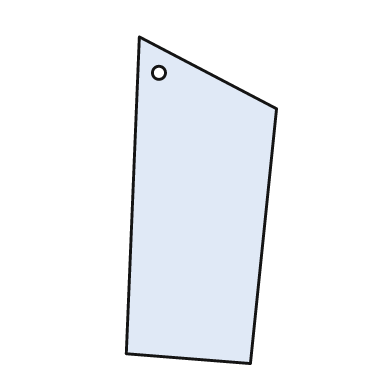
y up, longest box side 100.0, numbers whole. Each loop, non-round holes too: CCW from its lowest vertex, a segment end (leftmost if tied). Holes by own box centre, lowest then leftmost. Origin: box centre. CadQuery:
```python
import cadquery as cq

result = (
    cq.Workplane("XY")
    .moveTo(15.0, -50.0)
    .lineTo(23.0, 28.0)
    .lineTo(-19.0, 50.0)
    .lineTo(-23.0, -47.0)
    .close()
    .moveTo(-13.0, 39.0)
    .circle(2.0)
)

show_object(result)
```